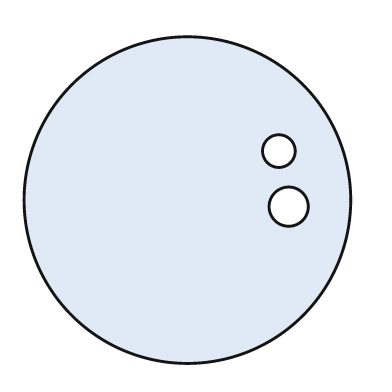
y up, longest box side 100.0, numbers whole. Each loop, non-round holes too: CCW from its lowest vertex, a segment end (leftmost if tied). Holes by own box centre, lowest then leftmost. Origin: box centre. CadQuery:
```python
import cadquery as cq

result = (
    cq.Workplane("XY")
    .moveTo(0.0, 0.0)
    .circle(50.0)
    .moveTo(31.0, -2.0)
    .circle(6.0)
    .moveTo(28.0, 15.0)
    .circle(5.0)
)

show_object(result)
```